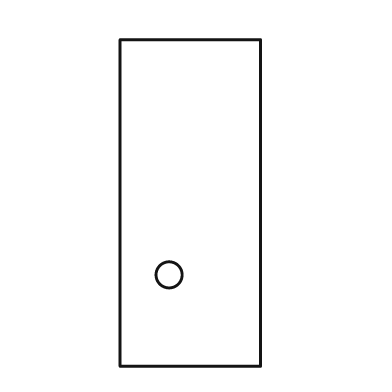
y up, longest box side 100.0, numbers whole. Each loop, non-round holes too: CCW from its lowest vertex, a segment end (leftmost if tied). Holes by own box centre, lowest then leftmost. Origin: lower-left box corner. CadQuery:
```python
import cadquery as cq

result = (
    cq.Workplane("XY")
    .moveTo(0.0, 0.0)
    .lineTo(43.0, 0.0)
    .lineTo(43.0, 100.0)
    .lineTo(0.0, 100.0)
    .close()
    .moveTo(15.0, 28.0)
    .circle(4.0)
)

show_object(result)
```